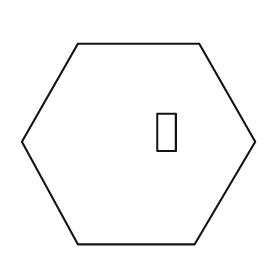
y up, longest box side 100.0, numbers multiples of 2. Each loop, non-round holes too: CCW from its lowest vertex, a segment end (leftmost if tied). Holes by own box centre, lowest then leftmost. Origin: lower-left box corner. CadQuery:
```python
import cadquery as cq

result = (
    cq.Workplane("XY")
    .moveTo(24.0, 0.0)
    .lineTo(74.0, 0.0)
    .lineTo(100.0, 44.0)
    .lineTo(76.0, 86.0)
    .lineTo(24.0, 86.0)
    .lineTo(0.0, 44.0)
    .close()
    .moveTo(58.0, 40.0)
    .lineTo(66.0, 40.0)
    .lineTo(66.0, 56.0)
    .lineTo(58.0, 56.0)
    .close()
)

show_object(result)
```